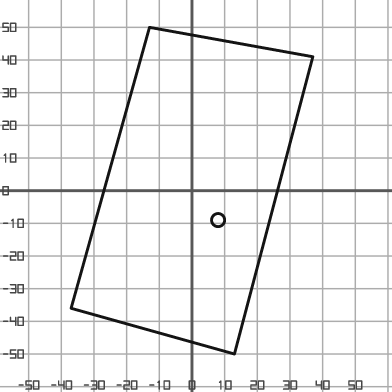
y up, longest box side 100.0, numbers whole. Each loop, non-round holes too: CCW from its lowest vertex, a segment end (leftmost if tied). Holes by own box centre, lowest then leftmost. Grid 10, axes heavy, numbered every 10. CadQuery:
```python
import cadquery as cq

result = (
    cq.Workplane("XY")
    .moveTo(13.0, -50.0)
    .lineTo(37.0, 41.0)
    .lineTo(-13.0, 50.0)
    .lineTo(-37.0, -36.0)
    .close()
    .moveTo(8.0, -9.0)
    .circle(2.0)
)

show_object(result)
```